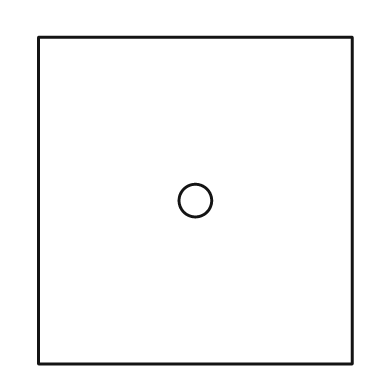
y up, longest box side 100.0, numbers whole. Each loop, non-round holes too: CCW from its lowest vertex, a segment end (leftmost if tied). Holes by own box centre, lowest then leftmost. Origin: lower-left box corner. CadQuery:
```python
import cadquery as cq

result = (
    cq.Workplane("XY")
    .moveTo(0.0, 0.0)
    .lineTo(96.0, 0.0)
    .lineTo(96.0, 100.0)
    .lineTo(0.0, 100.0)
    .close()
    .moveTo(48.0, 50.0)
    .circle(5.0)
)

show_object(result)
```